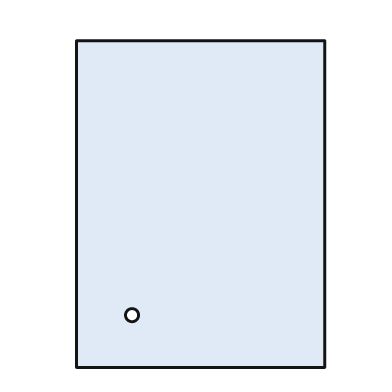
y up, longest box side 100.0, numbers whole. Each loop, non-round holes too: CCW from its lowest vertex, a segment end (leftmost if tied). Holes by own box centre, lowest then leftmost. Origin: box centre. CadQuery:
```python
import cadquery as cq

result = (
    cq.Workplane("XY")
    .moveTo(-38.0, -50.0)
    .lineTo(38.0, -50.0)
    .lineTo(38.0, 50.0)
    .lineTo(-38.0, 50.0)
    .close()
    .moveTo(-21.0, -34.0)
    .circle(2.0)
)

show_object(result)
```